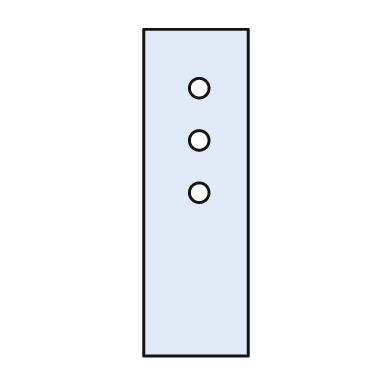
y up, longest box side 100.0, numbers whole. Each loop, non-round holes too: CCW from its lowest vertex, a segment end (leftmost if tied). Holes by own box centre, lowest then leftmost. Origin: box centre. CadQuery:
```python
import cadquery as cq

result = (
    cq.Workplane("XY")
    .moveTo(-16.0, -50.0)
    .lineTo(16.0, -50.0)
    .lineTo(16.0, 50.0)
    .lineTo(-16.0, 50.0)
    .close()
    .moveTo(1.0, 0.0)
    .circle(3.0)
    .moveTo(1.0, 16.0)
    .circle(3.0)
    .moveTo(1.0, 32.0)
    .circle(3.0)
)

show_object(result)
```